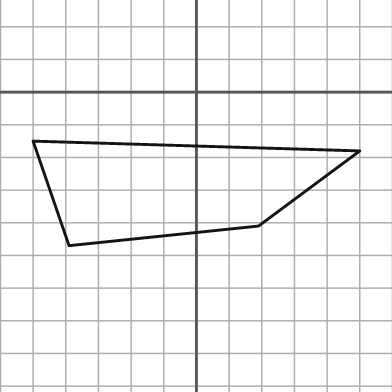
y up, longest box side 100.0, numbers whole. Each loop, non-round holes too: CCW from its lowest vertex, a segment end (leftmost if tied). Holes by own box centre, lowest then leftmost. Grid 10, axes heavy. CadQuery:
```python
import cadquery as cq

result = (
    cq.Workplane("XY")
    .moveTo(-39.0, -47.0)
    .lineTo(19.0, -41.0)
    .lineTo(50.0, -18.0)
    .lineTo(-50.0, -15.0)
    .close()
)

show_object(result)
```